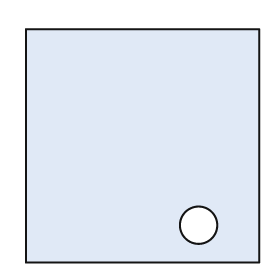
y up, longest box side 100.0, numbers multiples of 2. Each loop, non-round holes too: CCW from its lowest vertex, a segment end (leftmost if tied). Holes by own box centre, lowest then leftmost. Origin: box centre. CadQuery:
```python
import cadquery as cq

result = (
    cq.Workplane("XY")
    .moveTo(-50.0, -50.0)
    .lineTo(50.0, -50.0)
    .lineTo(50.0, 50.0)
    .lineTo(-50.0, 50.0)
    .close()
    .moveTo(24.0, -34.0)
    .circle(8.0)
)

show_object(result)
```